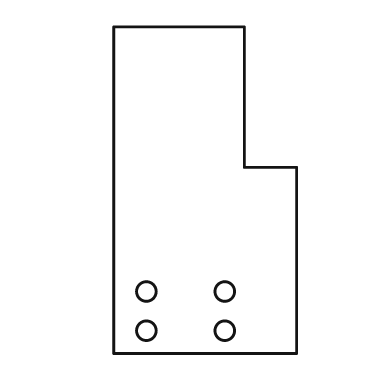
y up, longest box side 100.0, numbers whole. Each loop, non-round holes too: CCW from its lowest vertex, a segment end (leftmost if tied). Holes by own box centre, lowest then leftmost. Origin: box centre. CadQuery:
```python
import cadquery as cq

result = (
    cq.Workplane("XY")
    .moveTo(-28.0, -50.0)
    .lineTo(28.0, -50.0)
    .lineTo(28.0, 7.0)
    .lineTo(12.0, 7.0)
    .lineTo(12.0, 50.0)
    .lineTo(-28.0, 50.0)
    .close()
    .moveTo(-18.0, -43.0)
    .circle(3.0)
    .moveTo(6.0, -43.0)
    .circle(3.0)
    .moveTo(-18.0, -31.0)
    .circle(3.0)
    .moveTo(6.0, -31.0)
    .circle(3.0)
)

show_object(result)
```